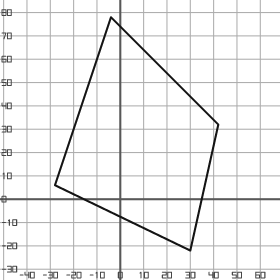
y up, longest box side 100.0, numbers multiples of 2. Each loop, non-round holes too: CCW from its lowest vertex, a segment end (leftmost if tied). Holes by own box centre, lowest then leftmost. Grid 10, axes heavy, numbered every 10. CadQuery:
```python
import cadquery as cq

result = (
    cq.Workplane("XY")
    .moveTo(30.0, -22.0)
    .lineTo(42.0, 32.0)
    .lineTo(-4.0, 78.0)
    .lineTo(-28.0, 6.0)
    .close()
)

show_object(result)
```